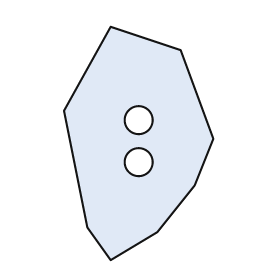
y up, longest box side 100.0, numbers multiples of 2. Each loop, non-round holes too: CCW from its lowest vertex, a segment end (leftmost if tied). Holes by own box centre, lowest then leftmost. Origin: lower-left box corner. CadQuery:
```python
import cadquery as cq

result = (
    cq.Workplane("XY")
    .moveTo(20.0, 0.0)
    .lineTo(40.0, 12.0)
    .lineTo(56.0, 32.0)
    .lineTo(64.0, 52.0)
    .lineTo(50.0, 90.0)
    .lineTo(20.0, 100.0)
    .lineTo(0.0, 64.0)
    .lineTo(10.0, 14.0)
    .close()
    .moveTo(32.0, 42.0)
    .circle(6.0)
    .moveTo(32.0, 60.0)
    .circle(6.0)
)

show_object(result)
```